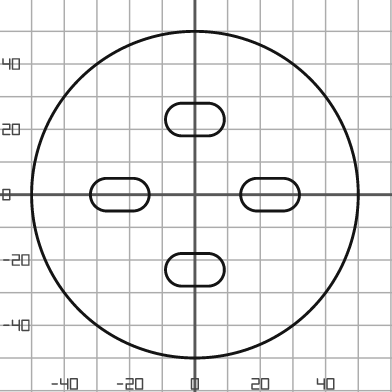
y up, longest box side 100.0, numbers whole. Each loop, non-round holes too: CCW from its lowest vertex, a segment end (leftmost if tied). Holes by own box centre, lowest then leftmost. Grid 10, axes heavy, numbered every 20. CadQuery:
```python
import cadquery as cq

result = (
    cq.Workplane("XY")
    .moveTo(0.0, 0.0)
    .circle(50.0)
    .moveTo(-4.0, -28.0)
    .lineTo(4.0, -28.0)
    .threePointArc((9.0, -23.0), (4.0, -18.0))
    .lineTo(-4.0, -18.0)
    .threePointArc((-9.0, -23.0), (-4.0, -28.0))
    .close()
    .moveTo(-27.0, -5.0)
    .lineTo(-19.0, -5.0)
    .threePointArc((-14.0, 0.0), (-19.0, 5.0))
    .lineTo(-27.0, 5.0)
    .threePointArc((-32.0, 0.0), (-27.0, -5.0))
    .close()
    .moveTo(19.0, -5.0)
    .lineTo(27.0, -5.0)
    .threePointArc((32.0, 0.0), (27.0, 5.0))
    .lineTo(19.0, 5.0)
    .threePointArc((14.0, 0.0), (19.0, -5.0))
    .close()
    .moveTo(-4.0, 18.0)
    .lineTo(4.0, 18.0)
    .threePointArc((9.0, 23.0), (4.0, 28.0))
    .lineTo(-4.0, 28.0)
    .threePointArc((-9.0, 23.0), (-4.0, 18.0))
    .close()
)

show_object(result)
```